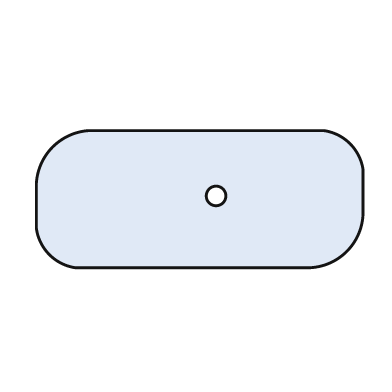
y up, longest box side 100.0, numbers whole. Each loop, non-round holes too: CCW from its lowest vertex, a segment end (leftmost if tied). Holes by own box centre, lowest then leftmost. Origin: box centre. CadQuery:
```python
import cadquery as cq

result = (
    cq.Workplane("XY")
    .moveTo(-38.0, -21.0)
    .lineTo(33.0, -21.0)
    .threePointArc((45.0, -16.0), (50.0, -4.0))
    .lineTo(50.0, 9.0)
    .threePointArc((46.0, 17.0), (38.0, 21.0))
    .lineTo(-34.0, 21.0)
    .threePointArc((-45.0, 16.0), (-50.0, 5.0))
    .lineTo(-50.0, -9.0)
    .threePointArc((-46.0, -17.0), (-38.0, -21.0))
    .close()
    .moveTo(5.0, 1.0)
    .circle(3.0)
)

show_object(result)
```